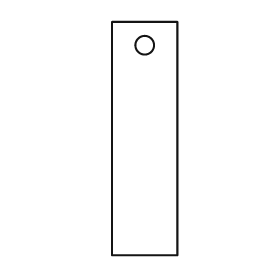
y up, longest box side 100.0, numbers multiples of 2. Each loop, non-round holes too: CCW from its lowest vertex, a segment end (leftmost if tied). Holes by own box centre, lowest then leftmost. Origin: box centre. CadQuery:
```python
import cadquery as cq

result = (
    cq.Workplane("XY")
    .moveTo(-14.0, -50.0)
    .lineTo(14.0, -50.0)
    .lineTo(14.0, 50.0)
    .lineTo(-14.0, 50.0)
    .close()
    .moveTo(0.0, 40.0)
    .circle(4.0)
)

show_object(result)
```